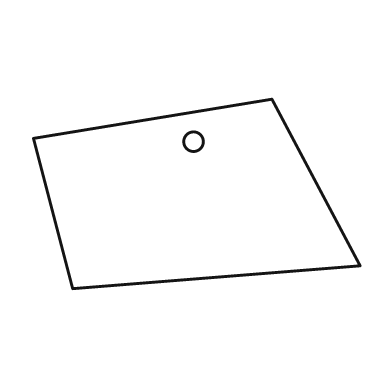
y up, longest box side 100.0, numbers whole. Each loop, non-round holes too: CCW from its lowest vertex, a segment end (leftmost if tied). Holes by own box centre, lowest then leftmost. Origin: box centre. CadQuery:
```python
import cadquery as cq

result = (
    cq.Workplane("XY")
    .moveTo(-38.0, -29.0)
    .lineTo(50.0, -22.0)
    .lineTo(23.0, 29.0)
    .lineTo(-50.0, 17.0)
    .close()
    .moveTo(-1.0, 16.0)
    .circle(3.0)
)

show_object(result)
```